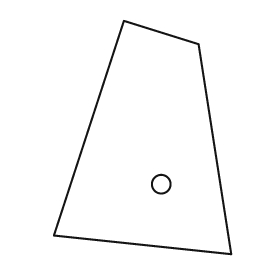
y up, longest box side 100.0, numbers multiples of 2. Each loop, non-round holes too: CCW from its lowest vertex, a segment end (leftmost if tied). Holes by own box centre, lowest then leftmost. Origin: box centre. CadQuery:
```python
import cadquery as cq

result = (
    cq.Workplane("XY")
    .moveTo(38.0, -50.0)
    .lineTo(24.0, 40.0)
    .lineTo(-8.0, 50.0)
    .lineTo(-38.0, -42.0)
    .close()
    .moveTo(8.0, -20.0)
    .circle(4.0)
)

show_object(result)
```